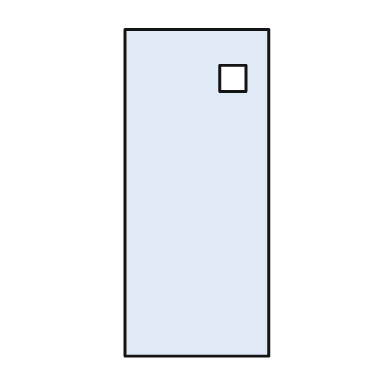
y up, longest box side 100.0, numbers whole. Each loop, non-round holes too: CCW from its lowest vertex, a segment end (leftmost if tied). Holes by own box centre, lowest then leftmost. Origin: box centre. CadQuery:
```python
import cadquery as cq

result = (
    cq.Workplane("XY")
    .moveTo(-22.0, -50.0)
    .lineTo(22.0, -50.0)
    .lineTo(22.0, 50.0)
    .lineTo(-22.0, 50.0)
    .close()
    .moveTo(7.0, 31.0)
    .lineTo(15.0, 31.0)
    .lineTo(15.0, 39.0)
    .lineTo(7.0, 39.0)
    .close()
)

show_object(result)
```